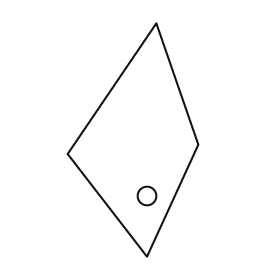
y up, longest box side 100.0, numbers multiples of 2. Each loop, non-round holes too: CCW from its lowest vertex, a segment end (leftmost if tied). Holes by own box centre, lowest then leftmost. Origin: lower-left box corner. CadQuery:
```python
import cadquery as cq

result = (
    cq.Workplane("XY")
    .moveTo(34.0, 0.0)
    .lineTo(56.0, 48.0)
    .lineTo(38.0, 100.0)
    .lineTo(0.0, 44.0)
    .close()
    .moveTo(34.0, 26.0)
    .circle(4.0)
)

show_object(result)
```